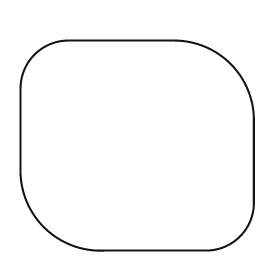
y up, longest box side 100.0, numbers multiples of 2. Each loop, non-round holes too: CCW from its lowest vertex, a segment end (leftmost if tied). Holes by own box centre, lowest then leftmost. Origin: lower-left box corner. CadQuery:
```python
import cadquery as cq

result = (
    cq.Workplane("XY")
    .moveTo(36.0, 0.0)
    .lineTo(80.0, 0.0)
    .threePointArc((94.0, 6.0), (100.0, 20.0))
    .lineTo(100.0, 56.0)
    .threePointArc((90.0, 80.0), (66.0, 90.0))
    .lineTo(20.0, 90.0)
    .threePointArc((6.0, 84.0), (0.0, 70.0))
    .lineTo(0.0, 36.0)
    .threePointArc((10.0, 10.0), (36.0, 0.0))
    .close()
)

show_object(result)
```